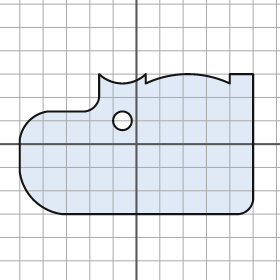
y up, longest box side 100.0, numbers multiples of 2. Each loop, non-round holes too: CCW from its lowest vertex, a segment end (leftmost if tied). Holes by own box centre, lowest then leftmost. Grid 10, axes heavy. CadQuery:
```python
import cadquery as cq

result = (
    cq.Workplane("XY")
    .moveTo(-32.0, -30.0)
    .lineTo(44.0, -30.0)
    .threePointArc((48.0, -28.0), (50.0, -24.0))
    .lineTo(50.0, 30.0)
    .lineTo(40.0, 30.0)
    .lineTo(40.0, 26.0)
    .threePointArc((22.0, 30.0), (4.0, 26.0))
    .lineTo(4.0, 30.0)
    .threePointArc((-6.0, 26.0), (-16.0, 30.0))
    .lineTo(-16.0, 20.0)
    .threePointArc((-18.0, 16.0), (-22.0, 14.0))
    .lineTo(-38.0, 14.0)
    .threePointArc((-46.0, 10.0), (-50.0, 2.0))
    .lineTo(-50.0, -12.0)
    .threePointArc((-44.0, -24.0), (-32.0, -30.0))
    .close()
    .moveTo(-6.0, 10.0)
    .circle(4.0)
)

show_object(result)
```